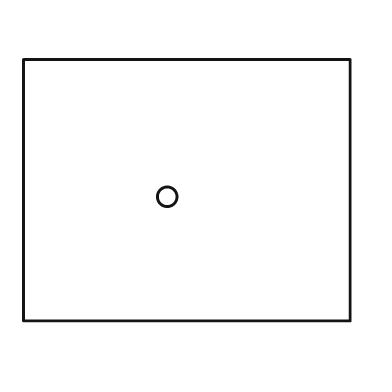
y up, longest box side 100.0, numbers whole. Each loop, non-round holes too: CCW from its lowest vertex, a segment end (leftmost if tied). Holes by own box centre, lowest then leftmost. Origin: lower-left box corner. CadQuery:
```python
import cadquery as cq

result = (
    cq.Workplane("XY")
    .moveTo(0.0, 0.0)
    .lineTo(100.0, 0.0)
    .lineTo(100.0, 80.0)
    .lineTo(0.0, 80.0)
    .close()
    .moveTo(44.0, 38.0)
    .circle(3.0)
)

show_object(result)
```